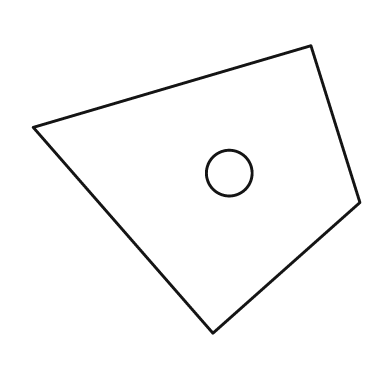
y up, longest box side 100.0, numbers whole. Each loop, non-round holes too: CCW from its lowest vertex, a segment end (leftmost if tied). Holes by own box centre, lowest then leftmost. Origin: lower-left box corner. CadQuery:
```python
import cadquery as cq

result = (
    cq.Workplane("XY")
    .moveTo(55.0, 0.0)
    .lineTo(100.0, 40.0)
    .lineTo(85.0, 88.0)
    .lineTo(0.0, 63.0)
    .close()
    .moveTo(60.0, 49.0)
    .circle(7.0)
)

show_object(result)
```